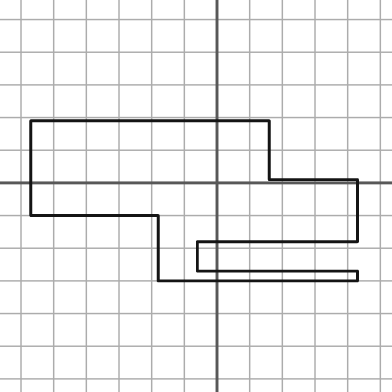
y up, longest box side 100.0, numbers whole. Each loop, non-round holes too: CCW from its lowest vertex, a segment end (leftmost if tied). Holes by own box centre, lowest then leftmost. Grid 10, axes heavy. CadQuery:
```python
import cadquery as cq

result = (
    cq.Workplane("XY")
    .moveTo(-18.0, -30.0)
    .lineTo(43.0, -30.0)
    .lineTo(43.0, -27.0)
    .lineTo(-6.0, -27.0)
    .lineTo(-6.0, -18.0)
    .lineTo(43.0, -18.0)
    .lineTo(43.0, 1.0)
    .lineTo(16.0, 1.0)
    .lineTo(16.0, 19.0)
    .lineTo(-57.0, 19.0)
    .lineTo(-57.0, -10.0)
    .lineTo(-18.0, -10.0)
    .close()
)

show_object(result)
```